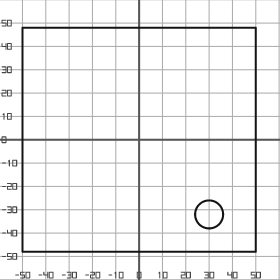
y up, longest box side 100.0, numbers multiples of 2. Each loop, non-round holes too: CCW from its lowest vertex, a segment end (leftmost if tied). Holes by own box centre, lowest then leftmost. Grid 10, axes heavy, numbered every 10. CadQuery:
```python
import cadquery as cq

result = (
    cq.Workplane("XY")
    .moveTo(-50.0, -48.0)
    .lineTo(50.0, -48.0)
    .lineTo(50.0, 48.0)
    .lineTo(-50.0, 48.0)
    .close()
    .moveTo(30.0, -32.0)
    .circle(6.0)
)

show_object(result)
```